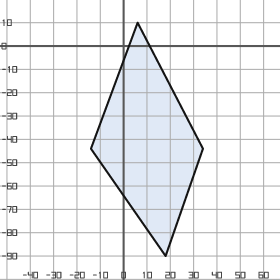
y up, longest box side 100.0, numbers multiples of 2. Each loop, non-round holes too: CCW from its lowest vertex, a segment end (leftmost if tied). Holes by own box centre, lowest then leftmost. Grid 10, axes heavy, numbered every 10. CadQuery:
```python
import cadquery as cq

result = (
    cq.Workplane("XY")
    .moveTo(18.0, -90.0)
    .lineTo(34.0, -44.0)
    .lineTo(6.0, 10.0)
    .lineTo(-14.0, -44.0)
    .close()
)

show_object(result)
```